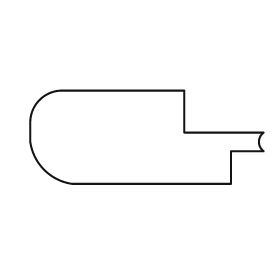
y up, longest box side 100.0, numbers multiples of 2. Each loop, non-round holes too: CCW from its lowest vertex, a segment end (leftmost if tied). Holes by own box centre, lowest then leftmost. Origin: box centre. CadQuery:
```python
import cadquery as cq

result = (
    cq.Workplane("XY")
    .moveTo(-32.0, -20.0)
    .lineTo(36.0, -20.0)
    .lineTo(36.0, -6.0)
    .lineTo(50.0, -6.0)
    .threePointArc((48.0, -2.0), (50.0, 2.0))
    .lineTo(16.0, 2.0)
    .lineTo(16.0, 20.0)
    .lineTo(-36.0, 20.0)
    .threePointArc((-46.0, 16.0), (-50.0, 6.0))
    .lineTo(-50.0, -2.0)
    .threePointArc((-44.0, -14.0), (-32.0, -20.0))
    .close()
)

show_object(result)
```